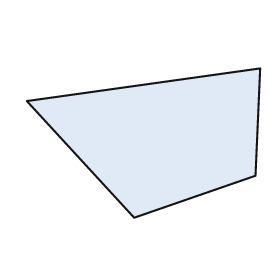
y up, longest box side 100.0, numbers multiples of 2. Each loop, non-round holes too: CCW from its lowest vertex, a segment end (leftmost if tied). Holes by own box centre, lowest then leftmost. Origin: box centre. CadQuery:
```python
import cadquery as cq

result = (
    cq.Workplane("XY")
    .moveTo(-4.0, -32.0)
    .lineTo(48.0, -14.0)
    .lineTo(50.0, 32.0)
    .lineTo(-50.0, 18.0)
    .close()
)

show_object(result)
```